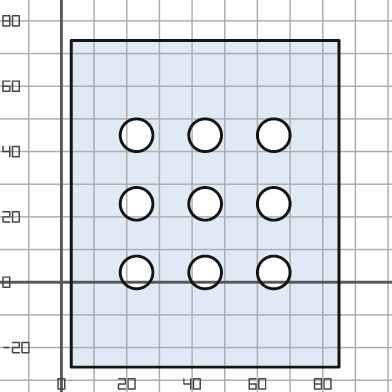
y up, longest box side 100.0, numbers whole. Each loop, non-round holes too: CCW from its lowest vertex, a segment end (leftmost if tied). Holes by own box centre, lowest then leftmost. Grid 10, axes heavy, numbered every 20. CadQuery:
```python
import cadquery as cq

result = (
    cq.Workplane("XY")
    .moveTo(3.0, -26.0)
    .lineTo(85.0, -26.0)
    .lineTo(85.0, 74.0)
    .lineTo(3.0, 74.0)
    .close()
    .moveTo(23.0, 3.0)
    .circle(5.0)
    .moveTo(44.0, 3.0)
    .circle(5.0)
    .moveTo(65.0, 3.0)
    .circle(5.0)
    .moveTo(23.0, 24.0)
    .circle(5.0)
    .moveTo(44.0, 24.0)
    .circle(5.0)
    .moveTo(65.0, 24.0)
    .circle(5.0)
    .moveTo(23.0, 45.0)
    .circle(5.0)
    .moveTo(44.0, 45.0)
    .circle(5.0)
    .moveTo(65.0, 45.0)
    .circle(5.0)
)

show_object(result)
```